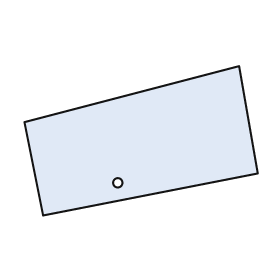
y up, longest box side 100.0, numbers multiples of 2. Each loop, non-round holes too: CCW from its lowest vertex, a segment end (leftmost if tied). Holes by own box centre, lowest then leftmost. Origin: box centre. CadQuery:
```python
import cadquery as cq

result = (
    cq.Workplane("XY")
    .moveTo(-42.0, -32.0)
    .lineTo(50.0, -14.0)
    .lineTo(42.0, 32.0)
    .lineTo(-50.0, 8.0)
    .close()
    .moveTo(-10.0, -18.0)
    .circle(2.0)
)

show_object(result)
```